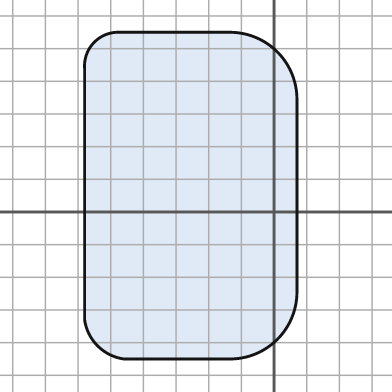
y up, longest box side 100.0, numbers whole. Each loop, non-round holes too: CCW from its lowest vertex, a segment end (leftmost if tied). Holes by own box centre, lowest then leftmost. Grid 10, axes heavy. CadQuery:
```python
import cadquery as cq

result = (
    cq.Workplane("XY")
    .moveTo(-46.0, -45.0)
    .lineTo(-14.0, -45.0)
    .threePointArc((1.0, -39.0), (7.0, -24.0))
    .lineTo(7.0, 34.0)
    .threePointArc((1.0, 49.0), (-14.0, 55.0))
    .lineTo(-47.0, 55.0)
    .threePointArc((-55.0, 52.0), (-58.0, 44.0))
    .lineTo(-58.0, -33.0)
    .threePointArc((-54.0, -41.0), (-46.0, -45.0))
    .close()
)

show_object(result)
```